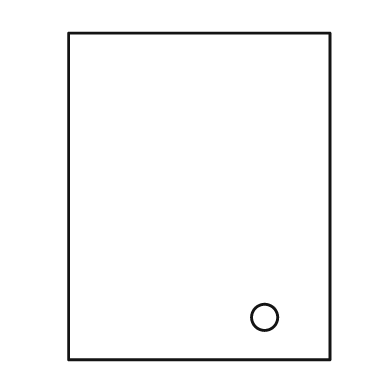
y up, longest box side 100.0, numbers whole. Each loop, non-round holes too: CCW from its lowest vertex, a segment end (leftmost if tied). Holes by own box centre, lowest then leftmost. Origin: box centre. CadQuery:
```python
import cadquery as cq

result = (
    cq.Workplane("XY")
    .moveTo(-40.0, -50.0)
    .lineTo(40.0, -50.0)
    .lineTo(40.0, 50.0)
    .lineTo(-40.0, 50.0)
    .close()
    .moveTo(20.0, -37.0)
    .circle(4.0)
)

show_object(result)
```